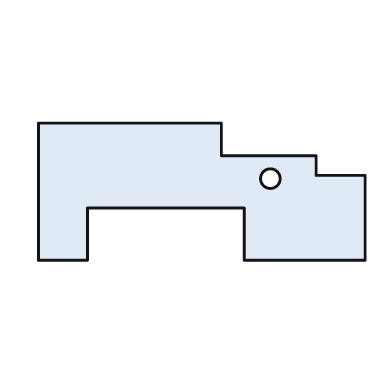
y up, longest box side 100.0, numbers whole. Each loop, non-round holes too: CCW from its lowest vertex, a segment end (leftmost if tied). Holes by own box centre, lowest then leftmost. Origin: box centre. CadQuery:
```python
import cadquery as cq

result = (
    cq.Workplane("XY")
    .moveTo(-50.0, -21.0)
    .lineTo(-35.0, -21.0)
    .lineTo(-35.0, -5.0)
    .lineTo(13.0, -5.0)
    .lineTo(13.0, -21.0)
    .lineTo(50.0, -21.0)
    .lineTo(50.0, 5.0)
    .lineTo(35.0, 5.0)
    .lineTo(35.0, 11.0)
    .lineTo(6.0, 11.0)
    .lineTo(6.0, 21.0)
    .lineTo(-50.0, 21.0)
    .close()
    .moveTo(21.0, 4.0)
    .circle(3.0)
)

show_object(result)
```